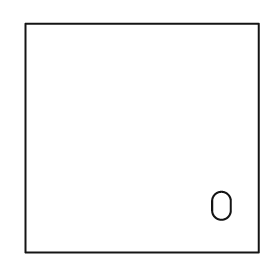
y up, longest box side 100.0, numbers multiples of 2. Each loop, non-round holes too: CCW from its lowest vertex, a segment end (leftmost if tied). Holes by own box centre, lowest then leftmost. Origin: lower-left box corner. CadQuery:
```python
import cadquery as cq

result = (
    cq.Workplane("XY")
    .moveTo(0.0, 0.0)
    .lineTo(100.0, 0.0)
    .lineTo(100.0, 98.0)
    .lineTo(0.0, 98.0)
    .close()
    .moveTo(80.0, 18.0)
    .threePointArc((84.0, 14.0), (88.0, 18.0))
    .lineTo(88.0, 22.0)
    .threePointArc((84.0, 26.0), (80.0, 22.0))
    .close()
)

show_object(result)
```